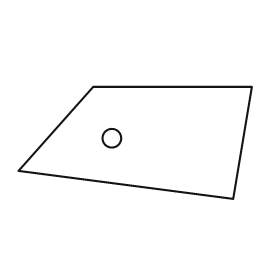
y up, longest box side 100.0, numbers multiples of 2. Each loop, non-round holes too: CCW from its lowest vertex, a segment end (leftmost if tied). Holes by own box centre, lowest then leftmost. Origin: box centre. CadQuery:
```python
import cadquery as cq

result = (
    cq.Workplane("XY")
    .moveTo(42.0, -24.0)
    .lineTo(50.0, 24.0)
    .lineTo(-18.0, 24.0)
    .lineTo(-50.0, -12.0)
    .close()
    .moveTo(-10.0, 2.0)
    .circle(4.0)
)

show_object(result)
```